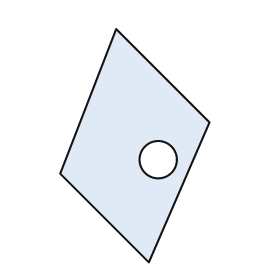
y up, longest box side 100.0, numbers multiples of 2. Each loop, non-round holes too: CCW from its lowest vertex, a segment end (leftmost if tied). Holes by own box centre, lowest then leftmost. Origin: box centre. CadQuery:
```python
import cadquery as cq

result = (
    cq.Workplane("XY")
    .moveTo(6.0, -50.0)
    .lineTo(32.0, 10.0)
    .lineTo(-8.0, 50.0)
    .lineTo(-32.0, -12.0)
    .close()
    .moveTo(10.0, -6.0)
    .circle(8.0)
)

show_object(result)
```